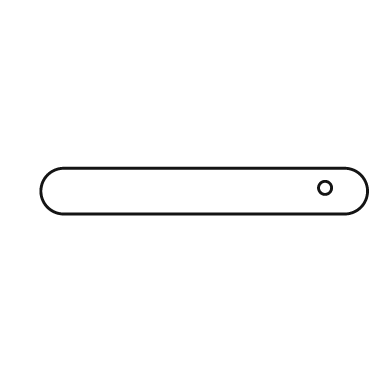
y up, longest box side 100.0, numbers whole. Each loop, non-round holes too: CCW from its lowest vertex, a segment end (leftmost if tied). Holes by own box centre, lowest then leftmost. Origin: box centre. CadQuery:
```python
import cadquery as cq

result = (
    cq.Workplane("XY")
    .moveTo(-43.0, -7.0)
    .lineTo(43.0, -7.0)
    .threePointArc((50.0, 0.0), (43.0, 7.0))
    .lineTo(-43.0, 7.0)
    .threePointArc((-50.0, 0.0), (-43.0, -7.0))
    .close()
    .moveTo(37.0, 1.0)
    .circle(2.0)
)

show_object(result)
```